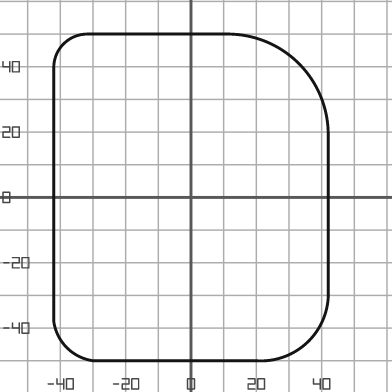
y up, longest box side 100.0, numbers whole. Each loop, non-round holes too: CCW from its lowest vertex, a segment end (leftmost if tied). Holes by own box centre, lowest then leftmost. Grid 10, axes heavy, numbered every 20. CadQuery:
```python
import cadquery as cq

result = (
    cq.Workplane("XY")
    .moveTo(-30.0, -50.0)
    .lineTo(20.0, -50.0)
    .threePointArc((36.0, -44.0), (42.0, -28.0))
    .lineTo(42.0, 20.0)
    .threePointArc((33.0, 41.0), (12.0, 50.0))
    .lineTo(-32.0, 50.0)
    .threePointArc((-39.0, 47.0), (-42.0, 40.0))
    .lineTo(-42.0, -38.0)
    .threePointArc((-38.0, -46.0), (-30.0, -50.0))
    .close()
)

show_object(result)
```